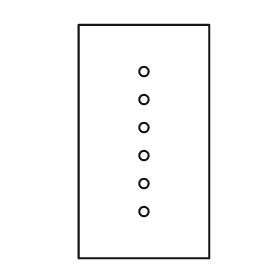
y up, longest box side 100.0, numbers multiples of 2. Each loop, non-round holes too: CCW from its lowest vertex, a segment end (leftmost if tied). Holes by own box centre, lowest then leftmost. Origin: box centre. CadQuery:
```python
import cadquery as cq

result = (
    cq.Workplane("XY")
    .moveTo(-28.0, -50.0)
    .lineTo(28.0, -50.0)
    .lineTo(28.0, 50.0)
    .lineTo(-28.0, 50.0)
    .close()
    .moveTo(0.0, -30.0)
    .circle(2.0)
    .moveTo(0.0, -18.0)
    .circle(2.0)
    .moveTo(0.0, -6.0)
    .circle(2.0)
    .moveTo(0.0, 6.0)
    .circle(2.0)
    .moveTo(0.0, 18.0)
    .circle(2.0)
    .moveTo(0.0, 30.0)
    .circle(2.0)
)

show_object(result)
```